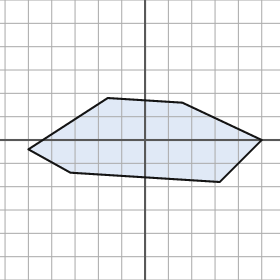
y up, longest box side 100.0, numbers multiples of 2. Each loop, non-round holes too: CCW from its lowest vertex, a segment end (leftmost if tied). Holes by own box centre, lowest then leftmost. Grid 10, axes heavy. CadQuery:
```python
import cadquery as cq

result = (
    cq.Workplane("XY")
    .moveTo(32.0, -18.0)
    .lineTo(50.0, 0.0)
    .lineTo(16.0, 16.0)
    .lineTo(-16.0, 18.0)
    .lineTo(-50.0, -4.0)
    .lineTo(-32.0, -14.0)
    .close()
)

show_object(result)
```